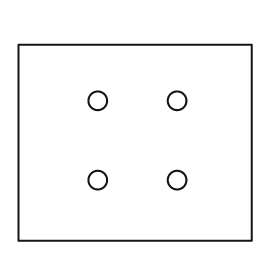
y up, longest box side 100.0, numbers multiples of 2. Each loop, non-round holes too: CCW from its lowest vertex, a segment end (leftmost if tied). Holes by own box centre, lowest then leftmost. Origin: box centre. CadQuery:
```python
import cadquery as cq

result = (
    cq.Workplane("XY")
    .moveTo(-50.0, -42.0)
    .lineTo(50.0, -42.0)
    .lineTo(50.0, 42.0)
    .lineTo(-50.0, 42.0)
    .close()
    .moveTo(-16.0, -16.0)
    .circle(4.0)
    .moveTo(18.0, -16.0)
    .circle(4.0)
    .moveTo(-16.0, 18.0)
    .circle(4.0)
    .moveTo(18.0, 18.0)
    .circle(4.0)
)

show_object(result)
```